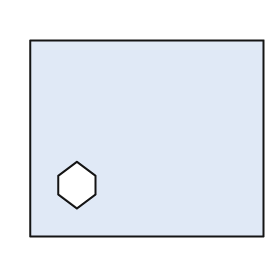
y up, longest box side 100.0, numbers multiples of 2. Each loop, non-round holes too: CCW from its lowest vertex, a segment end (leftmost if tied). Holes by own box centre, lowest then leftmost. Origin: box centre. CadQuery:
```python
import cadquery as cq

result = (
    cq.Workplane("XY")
    .moveTo(-50.0, -42.0)
    .lineTo(50.0, -42.0)
    .lineTo(50.0, 42.0)
    .lineTo(-50.0, 42.0)
    .close()
    .moveTo(-30.0, -30.0)
    .lineTo(-22.0, -24.0)
    .lineTo(-22.0, -16.0)
    .lineTo(-30.0, -10.0)
    .lineTo(-38.0, -16.0)
    .lineTo(-38.0, -24.0)
    .close()
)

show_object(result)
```